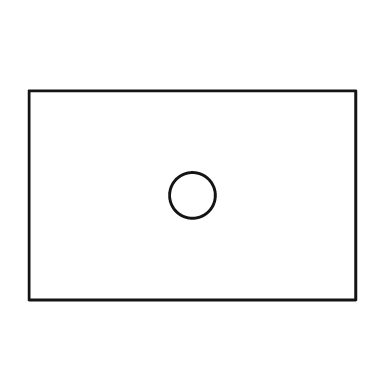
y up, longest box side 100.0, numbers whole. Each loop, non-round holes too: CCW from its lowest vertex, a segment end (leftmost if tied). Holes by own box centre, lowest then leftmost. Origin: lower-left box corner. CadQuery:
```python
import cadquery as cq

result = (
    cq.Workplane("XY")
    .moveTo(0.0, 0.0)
    .lineTo(100.0, 0.0)
    .lineTo(100.0, 64.0)
    .lineTo(0.0, 64.0)
    .close()
    .moveTo(50.0, 32.0)
    .circle(7.0)
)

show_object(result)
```